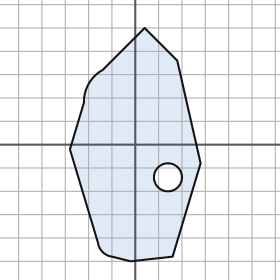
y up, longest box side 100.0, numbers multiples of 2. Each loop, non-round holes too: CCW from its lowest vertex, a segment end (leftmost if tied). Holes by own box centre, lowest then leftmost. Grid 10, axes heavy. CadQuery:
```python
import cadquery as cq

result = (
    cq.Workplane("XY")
    .moveTo(-2.0, -50.0)
    .lineTo(16.0, -48.0)
    .lineTo(28.0, -8.0)
    .lineTo(18.0, 36.0)
    .lineTo(4.0, 50.0)
    .lineTo(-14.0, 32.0)
    .threePointArc((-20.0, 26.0), (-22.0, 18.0))
    .lineTo(-28.0, -2.0)
    .lineTo(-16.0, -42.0)
    .threePointArc((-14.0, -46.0), (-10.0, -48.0))
    .close()
    .moveTo(14.0, -14.0)
    .circle(6.0)
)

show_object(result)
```